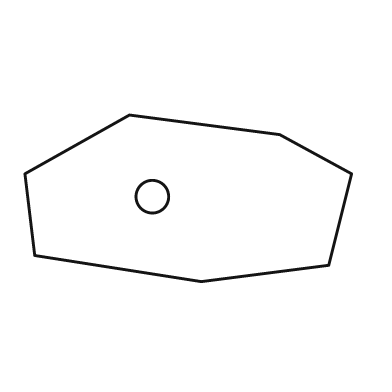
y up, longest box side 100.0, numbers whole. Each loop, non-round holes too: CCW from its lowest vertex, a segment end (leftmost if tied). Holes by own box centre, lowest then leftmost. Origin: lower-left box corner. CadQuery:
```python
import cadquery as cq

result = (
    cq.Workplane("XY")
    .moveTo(54.0, 0.0)
    .lineTo(93.0, 5.0)
    .lineTo(100.0, 33.0)
    .lineTo(78.0, 45.0)
    .lineTo(32.0, 51.0)
    .lineTo(0.0, 33.0)
    .lineTo(3.0, 8.0)
    .close()
    .moveTo(39.0, 26.0)
    .circle(5.0)
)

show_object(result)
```